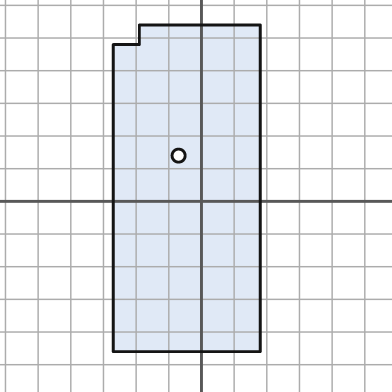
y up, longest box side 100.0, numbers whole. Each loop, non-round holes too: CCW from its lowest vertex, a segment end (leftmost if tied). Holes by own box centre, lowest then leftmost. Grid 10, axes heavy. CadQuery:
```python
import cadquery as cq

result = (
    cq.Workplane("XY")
    .moveTo(-27.0, -46.0)
    .lineTo(18.0, -46.0)
    .lineTo(18.0, 54.0)
    .lineTo(-19.0, 54.0)
    .lineTo(-19.0, 48.0)
    .lineTo(-27.0, 48.0)
    .close()
    .moveTo(-7.0, 14.0)
    .circle(2.0)
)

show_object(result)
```